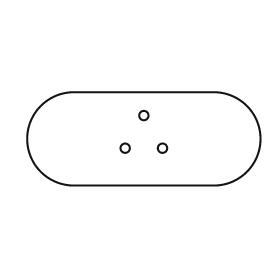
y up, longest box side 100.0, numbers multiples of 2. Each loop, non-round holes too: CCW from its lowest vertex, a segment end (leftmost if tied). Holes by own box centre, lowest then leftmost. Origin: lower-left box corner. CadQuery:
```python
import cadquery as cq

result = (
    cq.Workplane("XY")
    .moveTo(20.0, 0.0)
    .lineTo(80.0, 0.0)
    .threePointArc((100.0, 20.0), (80.0, 40.0))
    .lineTo(20.0, 40.0)
    .threePointArc((0.0, 20.0), (20.0, 0.0))
    .close()
    .moveTo(42.0, 16.0)
    .circle(2.0)
    .moveTo(58.0, 16.0)
    .circle(2.0)
    .moveTo(50.0, 30.0)
    .circle(2.0)
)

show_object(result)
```